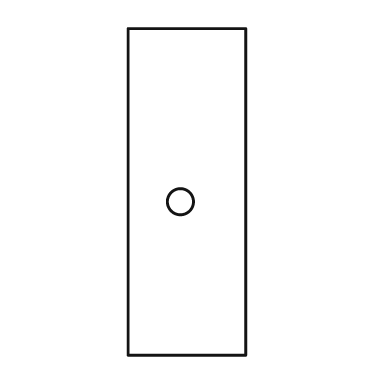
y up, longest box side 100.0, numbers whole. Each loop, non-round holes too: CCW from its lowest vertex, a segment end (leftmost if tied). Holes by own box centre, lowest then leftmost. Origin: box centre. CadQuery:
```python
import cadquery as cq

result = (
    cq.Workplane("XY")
    .moveTo(-18.0, -50.0)
    .lineTo(18.0, -50.0)
    .lineTo(18.0, 50.0)
    .lineTo(-18.0, 50.0)
    .close()
    .moveTo(-2.0, -3.0)
    .circle(4.0)
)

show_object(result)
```